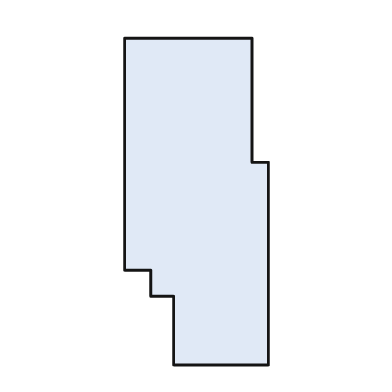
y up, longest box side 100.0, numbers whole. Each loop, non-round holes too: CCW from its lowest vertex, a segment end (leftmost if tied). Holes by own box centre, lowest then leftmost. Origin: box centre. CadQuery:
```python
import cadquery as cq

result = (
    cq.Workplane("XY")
    .moveTo(-7.0, -50.0)
    .lineTo(22.0, -50.0)
    .lineTo(22.0, 12.0)
    .lineTo(17.0, 12.0)
    .lineTo(17.0, 50.0)
    .lineTo(-22.0, 50.0)
    .lineTo(-22.0, -21.0)
    .lineTo(-14.0, -21.0)
    .lineTo(-14.0, -29.0)
    .lineTo(-7.0, -29.0)
    .close()
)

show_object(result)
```